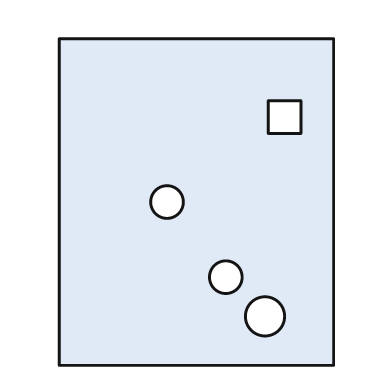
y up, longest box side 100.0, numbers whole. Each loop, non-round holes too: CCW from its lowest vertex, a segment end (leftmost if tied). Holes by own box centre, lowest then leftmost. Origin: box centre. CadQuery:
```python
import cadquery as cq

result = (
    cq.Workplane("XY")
    .moveTo(-42.0, -50.0)
    .lineTo(42.0, -50.0)
    .lineTo(42.0, 50.0)
    .lineTo(-42.0, 50.0)
    .close()
    .moveTo(21.0, -35.0)
    .circle(6.0)
    .moveTo(9.0, -23.0)
    .circle(5.0)
    .moveTo(-9.0, 0.0)
    .circle(5.0)
    .moveTo(22.0, 21.0)
    .lineTo(32.0, 21.0)
    .lineTo(32.0, 31.0)
    .lineTo(22.0, 31.0)
    .close()
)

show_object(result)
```